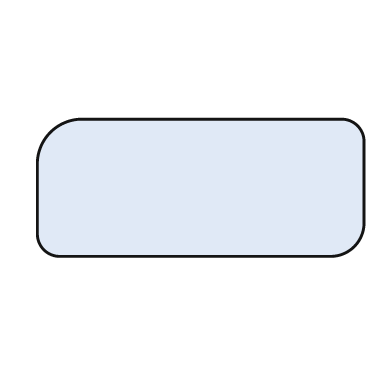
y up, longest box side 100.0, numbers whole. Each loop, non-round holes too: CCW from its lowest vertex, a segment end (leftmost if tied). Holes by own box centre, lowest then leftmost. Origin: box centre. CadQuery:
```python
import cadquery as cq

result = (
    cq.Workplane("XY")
    .moveTo(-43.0, -21.0)
    .lineTo(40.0, -21.0)
    .threePointArc((47.0, -18.0), (50.0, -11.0))
    .lineTo(50.0, 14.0)
    .threePointArc((48.0, 19.0), (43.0, 21.0))
    .lineTo(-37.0, 21.0)
    .threePointArc((-46.0, 17.0), (-50.0, 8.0))
    .lineTo(-50.0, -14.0)
    .threePointArc((-48.0, -19.0), (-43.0, -21.0))
    .close()
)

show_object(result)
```